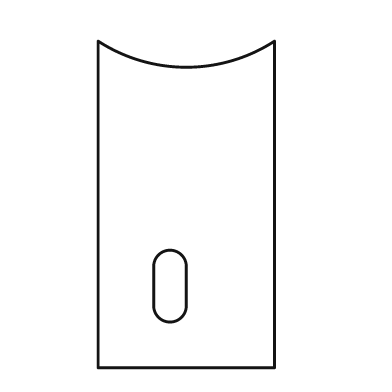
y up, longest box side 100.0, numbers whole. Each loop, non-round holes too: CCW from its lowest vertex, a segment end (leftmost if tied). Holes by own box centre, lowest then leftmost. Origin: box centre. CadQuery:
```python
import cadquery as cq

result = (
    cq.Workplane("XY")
    .moveTo(-27.0, -50.0)
    .lineTo(27.0, -50.0)
    .lineTo(27.0, 50.0)
    .threePointArc((0.0, 42.0), (-27.0, 50.0))
    .close()
    .moveTo(-10.0, -31.0)
    .threePointArc((-5.0, -36.0), (0.0, -31.0))
    .lineTo(0.0, -19.0)
    .threePointArc((-5.0, -14.0), (-10.0, -19.0))
    .close()
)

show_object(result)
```